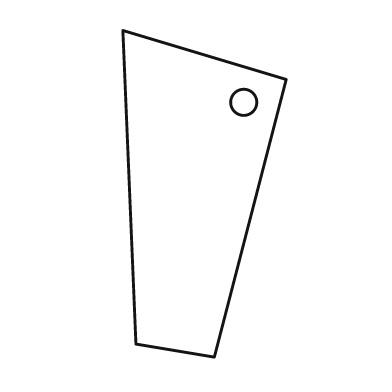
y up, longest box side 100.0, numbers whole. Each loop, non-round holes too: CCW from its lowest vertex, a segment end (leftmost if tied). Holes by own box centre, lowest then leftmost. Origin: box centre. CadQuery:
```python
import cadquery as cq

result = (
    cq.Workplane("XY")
    .moveTo(3.0, -50.0)
    .lineTo(25.0, 35.0)
    .lineTo(-25.0, 50.0)
    .lineTo(-21.0, -46.0)
    .close()
    .moveTo(12.0, 28.0)
    .circle(4.0)
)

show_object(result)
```